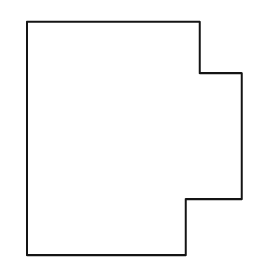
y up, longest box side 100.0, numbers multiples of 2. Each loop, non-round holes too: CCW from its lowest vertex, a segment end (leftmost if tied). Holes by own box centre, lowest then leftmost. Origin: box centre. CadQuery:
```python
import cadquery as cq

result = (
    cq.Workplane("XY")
    .moveTo(-46.0, -50.0)
    .lineTo(22.0, -50.0)
    .lineTo(22.0, -26.0)
    .lineTo(46.0, -26.0)
    .lineTo(46.0, 28.0)
    .lineTo(28.0, 28.0)
    .lineTo(28.0, 50.0)
    .lineTo(-46.0, 50.0)
    .close()
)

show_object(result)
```